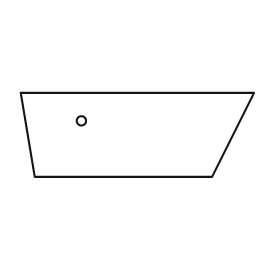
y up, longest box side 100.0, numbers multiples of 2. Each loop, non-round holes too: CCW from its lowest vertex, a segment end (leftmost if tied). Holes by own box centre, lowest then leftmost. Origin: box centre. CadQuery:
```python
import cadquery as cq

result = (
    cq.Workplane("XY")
    .moveTo(-44.0, -18.0)
    .lineTo(32.0, -18.0)
    .lineTo(50.0, 18.0)
    .lineTo(-50.0, 18.0)
    .close()
    .moveTo(-24.0, 6.0)
    .circle(2.0)
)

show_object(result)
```